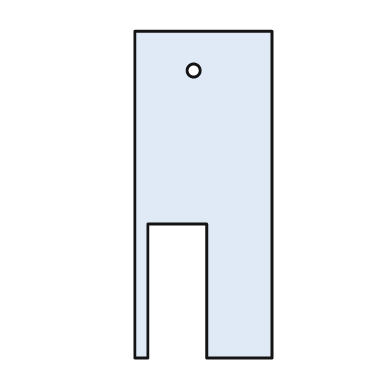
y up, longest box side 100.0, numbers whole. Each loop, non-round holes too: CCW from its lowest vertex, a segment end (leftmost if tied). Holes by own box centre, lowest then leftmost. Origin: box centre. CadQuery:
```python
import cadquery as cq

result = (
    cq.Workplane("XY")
    .moveTo(-21.0, -50.0)
    .lineTo(-17.0, -50.0)
    .lineTo(-17.0, -9.0)
    .lineTo(1.0, -9.0)
    .lineTo(1.0, -50.0)
    .lineTo(21.0, -50.0)
    .lineTo(21.0, 50.0)
    .lineTo(-21.0, 50.0)
    .close()
    .moveTo(-3.0, 38.0)
    .circle(2.0)
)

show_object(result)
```